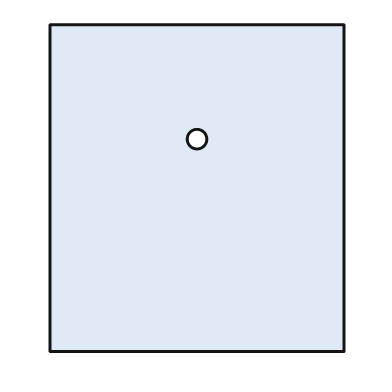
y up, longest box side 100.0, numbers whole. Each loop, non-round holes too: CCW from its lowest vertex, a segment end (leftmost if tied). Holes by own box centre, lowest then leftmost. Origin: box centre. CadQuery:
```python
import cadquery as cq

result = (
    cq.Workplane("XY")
    .moveTo(-45.0, -50.0)
    .lineTo(45.0, -50.0)
    .lineTo(45.0, 50.0)
    .lineTo(-45.0, 50.0)
    .close()
    .moveTo(0.0, 15.0)
    .circle(3.0)
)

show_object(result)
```